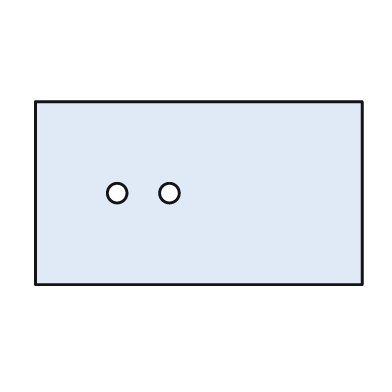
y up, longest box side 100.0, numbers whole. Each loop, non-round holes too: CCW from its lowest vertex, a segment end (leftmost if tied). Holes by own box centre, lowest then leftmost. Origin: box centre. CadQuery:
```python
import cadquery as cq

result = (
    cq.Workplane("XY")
    .moveTo(-50.0, -28.0)
    .lineTo(50.0, -28.0)
    .lineTo(50.0, 28.0)
    .lineTo(-50.0, 28.0)
    .close()
    .moveTo(-25.0, 0.0)
    .circle(3.0)
    .moveTo(-9.0, 0.0)
    .circle(3.0)
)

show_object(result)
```